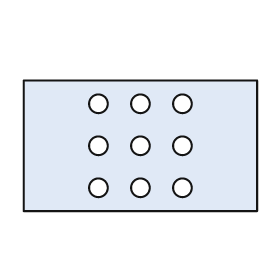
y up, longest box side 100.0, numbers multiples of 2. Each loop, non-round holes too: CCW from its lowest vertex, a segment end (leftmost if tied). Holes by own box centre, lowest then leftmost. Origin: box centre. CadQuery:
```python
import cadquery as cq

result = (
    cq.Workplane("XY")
    .moveTo(-50.0, -28.0)
    .lineTo(50.0, -28.0)
    .lineTo(50.0, 28.0)
    .lineTo(-50.0, 28.0)
    .close()
    .moveTo(-18.0, -18.0)
    .circle(4.0)
    .moveTo(0.0, -18.0)
    .circle(4.0)
    .moveTo(18.0, -18.0)
    .circle(4.0)
    .moveTo(-18.0, 0.0)
    .circle(4.0)
    .moveTo(0.0, 0.0)
    .circle(4.0)
    .moveTo(18.0, 0.0)
    .circle(4.0)
    .moveTo(-18.0, 18.0)
    .circle(4.0)
    .moveTo(0.0, 18.0)
    .circle(4.0)
    .moveTo(18.0, 18.0)
    .circle(4.0)
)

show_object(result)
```